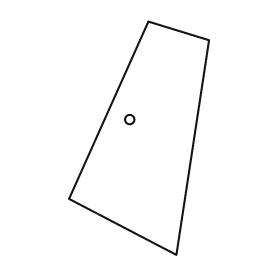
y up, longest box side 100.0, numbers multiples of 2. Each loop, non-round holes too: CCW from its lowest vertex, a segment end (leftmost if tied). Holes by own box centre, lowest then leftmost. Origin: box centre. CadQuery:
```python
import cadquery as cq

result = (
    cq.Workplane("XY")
    .moveTo(16.0, -50.0)
    .lineTo(30.0, 42.0)
    .lineTo(4.0, 50.0)
    .lineTo(-30.0, -26.0)
    .close()
    .moveTo(-4.0, 8.0)
    .circle(2.0)
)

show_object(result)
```